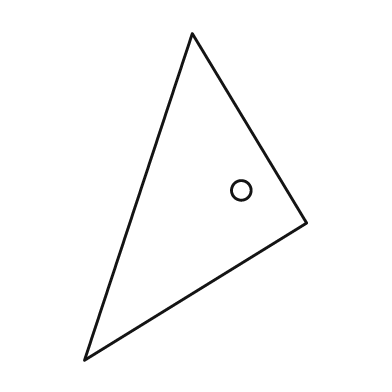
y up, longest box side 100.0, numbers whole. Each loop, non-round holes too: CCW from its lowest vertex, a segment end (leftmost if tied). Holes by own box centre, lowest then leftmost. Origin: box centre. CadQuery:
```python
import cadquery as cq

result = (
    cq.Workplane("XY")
    .moveTo(-34.0, -50.0)
    .lineTo(34.0, -8.0)
    .lineTo(-1.0, 50.0)
    .close()
    .moveTo(14.0, 2.0)
    .circle(3.0)
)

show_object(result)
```